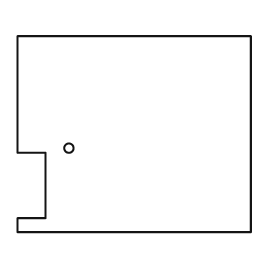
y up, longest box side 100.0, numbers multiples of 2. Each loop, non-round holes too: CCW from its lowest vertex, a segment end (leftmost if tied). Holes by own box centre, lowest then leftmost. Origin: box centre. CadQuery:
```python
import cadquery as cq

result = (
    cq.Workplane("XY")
    .moveTo(-50.0, -42.0)
    .lineTo(50.0, -42.0)
    .lineTo(50.0, 42.0)
    .lineTo(-50.0, 42.0)
    .lineTo(-50.0, -8.0)
    .lineTo(-38.0, -8.0)
    .lineTo(-38.0, -36.0)
    .lineTo(-50.0, -36.0)
    .close()
    .moveTo(-28.0, -6.0)
    .circle(2.0)
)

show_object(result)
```